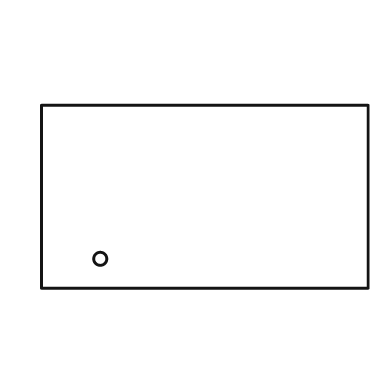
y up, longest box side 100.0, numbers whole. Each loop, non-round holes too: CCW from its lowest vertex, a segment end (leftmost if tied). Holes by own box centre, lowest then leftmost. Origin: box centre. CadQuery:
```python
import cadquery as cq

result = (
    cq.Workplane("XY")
    .moveTo(-50.0, -28.0)
    .lineTo(50.0, -28.0)
    .lineTo(50.0, 28.0)
    .lineTo(-50.0, 28.0)
    .close()
    .moveTo(-32.0, -19.0)
    .circle(2.0)
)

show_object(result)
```